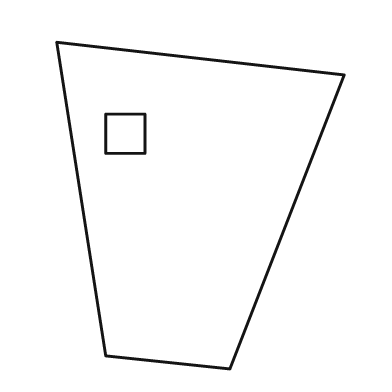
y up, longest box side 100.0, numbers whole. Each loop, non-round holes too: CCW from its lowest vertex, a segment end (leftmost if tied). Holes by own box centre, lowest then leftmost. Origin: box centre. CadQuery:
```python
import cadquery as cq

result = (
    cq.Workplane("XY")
    .moveTo(9.0, -50.0)
    .lineTo(44.0, 40.0)
    .lineTo(-44.0, 50.0)
    .lineTo(-29.0, -46.0)
    .close()
    .moveTo(-29.0, 16.0)
    .lineTo(-17.0, 16.0)
    .lineTo(-17.0, 28.0)
    .lineTo(-29.0, 28.0)
    .close()
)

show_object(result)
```